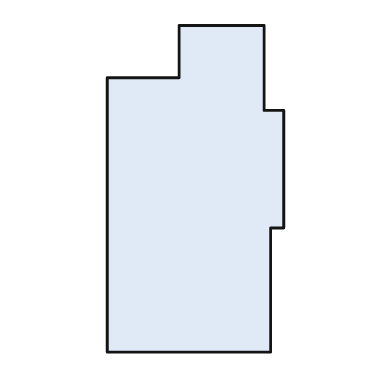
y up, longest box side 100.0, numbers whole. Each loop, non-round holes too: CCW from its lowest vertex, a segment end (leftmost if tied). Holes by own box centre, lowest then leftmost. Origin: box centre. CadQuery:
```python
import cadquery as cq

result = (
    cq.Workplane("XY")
    .moveTo(-27.0, -50.0)
    .lineTo(23.0, -50.0)
    .lineTo(23.0, -12.0)
    .lineTo(27.0, -12.0)
    .lineTo(27.0, 24.0)
    .lineTo(21.0, 24.0)
    .lineTo(21.0, 50.0)
    .lineTo(-5.0, 50.0)
    .lineTo(-5.0, 34.0)
    .lineTo(-27.0, 34.0)
    .close()
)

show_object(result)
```